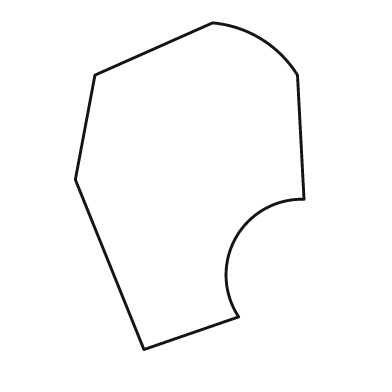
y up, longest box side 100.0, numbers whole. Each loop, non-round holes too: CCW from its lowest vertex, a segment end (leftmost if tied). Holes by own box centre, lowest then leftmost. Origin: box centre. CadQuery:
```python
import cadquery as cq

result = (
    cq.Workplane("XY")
    .moveTo(-14.0, -50.0)
    .lineTo(15.0, -40.0)
    .threePointArc((14.0, -16.0), (35.0, -4.0))
    .lineTo(33.0, 34.0)
    .threePointArc((22.0, 45.0), (7.0, 50.0))
    .lineTo(-29.0, 34.0)
    .lineTo(-35.0, 2.0)
    .close()
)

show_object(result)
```